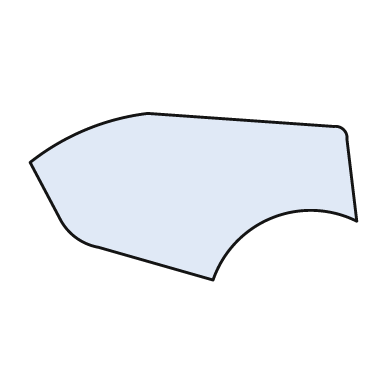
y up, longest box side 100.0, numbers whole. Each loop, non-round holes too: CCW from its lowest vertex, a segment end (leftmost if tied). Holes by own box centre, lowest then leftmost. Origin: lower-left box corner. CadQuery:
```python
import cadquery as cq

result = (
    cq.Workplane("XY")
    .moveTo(56.0, 0.0)
    .threePointArc((74.0, 19.0), (100.0, 18.0))
    .lineTo(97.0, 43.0)
    .threePointArc((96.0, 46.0), (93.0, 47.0))
    .lineTo(36.0, 51.0)
    .threePointArc((17.0, 46.0), (0.0, 36.0))
    .lineTo(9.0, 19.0)
    .threePointArc((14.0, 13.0), (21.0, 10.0))
    .close()
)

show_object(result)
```